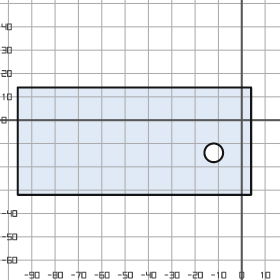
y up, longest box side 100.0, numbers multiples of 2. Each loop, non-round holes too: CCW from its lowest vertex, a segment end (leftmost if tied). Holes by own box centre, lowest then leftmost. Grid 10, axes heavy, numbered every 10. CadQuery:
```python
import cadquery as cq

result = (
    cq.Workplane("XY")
    .moveTo(-96.0, -32.0)
    .lineTo(4.0, -32.0)
    .lineTo(4.0, 14.0)
    .lineTo(-96.0, 14.0)
    .close()
    .moveTo(-12.0, -14.0)
    .circle(4.0)
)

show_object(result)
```